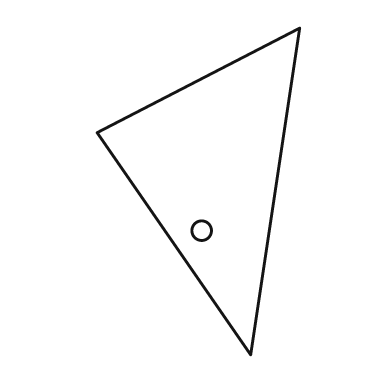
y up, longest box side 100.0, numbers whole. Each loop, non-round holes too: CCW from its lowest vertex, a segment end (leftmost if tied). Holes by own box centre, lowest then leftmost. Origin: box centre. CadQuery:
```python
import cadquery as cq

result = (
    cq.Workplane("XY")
    .moveTo(16.0, -50.0)
    .lineTo(31.0, 50.0)
    .lineTo(-31.0, 18.0)
    .close()
    .moveTo(1.0, -12.0)
    .circle(3.0)
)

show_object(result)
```